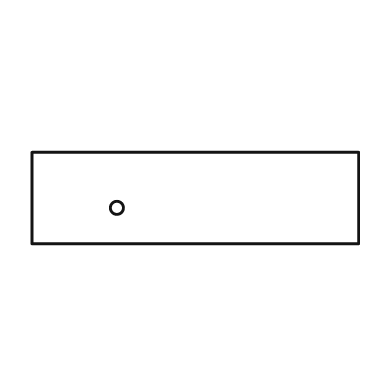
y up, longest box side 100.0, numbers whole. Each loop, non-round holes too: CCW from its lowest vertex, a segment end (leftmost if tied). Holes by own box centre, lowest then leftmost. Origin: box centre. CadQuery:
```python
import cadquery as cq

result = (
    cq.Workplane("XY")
    .moveTo(-50.0, -14.0)
    .lineTo(50.0, -14.0)
    .lineTo(50.0, 14.0)
    .lineTo(-50.0, 14.0)
    .close()
    .moveTo(-24.0, -3.0)
    .circle(2.0)
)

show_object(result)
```